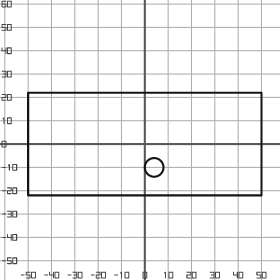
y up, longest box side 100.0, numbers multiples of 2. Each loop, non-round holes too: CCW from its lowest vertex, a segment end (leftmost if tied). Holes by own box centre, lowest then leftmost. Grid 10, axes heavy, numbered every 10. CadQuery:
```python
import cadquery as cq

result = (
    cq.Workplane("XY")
    .moveTo(-50.0, -22.0)
    .lineTo(50.0, -22.0)
    .lineTo(50.0, 22.0)
    .lineTo(-50.0, 22.0)
    .close()
    .moveTo(4.0, -10.0)
    .circle(4.0)
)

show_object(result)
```